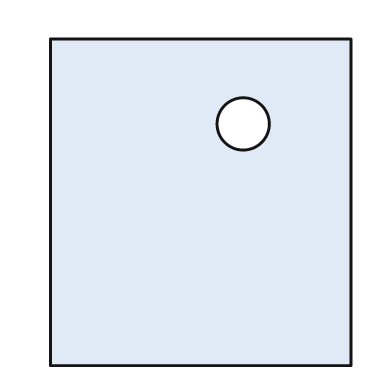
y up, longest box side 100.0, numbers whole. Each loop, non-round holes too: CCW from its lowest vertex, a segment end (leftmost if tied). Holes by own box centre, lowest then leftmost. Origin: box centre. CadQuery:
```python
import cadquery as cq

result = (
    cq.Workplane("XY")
    .moveTo(-46.0, -50.0)
    .lineTo(46.0, -50.0)
    .lineTo(46.0, 50.0)
    .lineTo(-46.0, 50.0)
    .close()
    .moveTo(13.0, 24.0)
    .circle(8.0)
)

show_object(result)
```